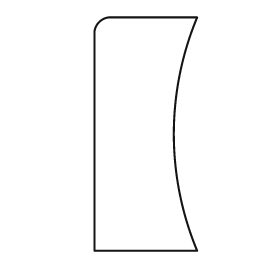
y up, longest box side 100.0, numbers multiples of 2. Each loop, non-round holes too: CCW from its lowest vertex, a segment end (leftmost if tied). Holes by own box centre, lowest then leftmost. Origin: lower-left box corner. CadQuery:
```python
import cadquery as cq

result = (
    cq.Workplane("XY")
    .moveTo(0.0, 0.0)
    .lineTo(44.0, 0.0)
    .threePointArc((34.0, 50.0), (44.0, 100.0))
    .lineTo(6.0, 100.0)
    .threePointArc((2.0, 98.0), (0.0, 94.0))
    .close()
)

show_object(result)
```